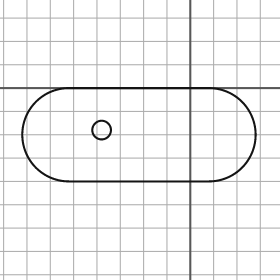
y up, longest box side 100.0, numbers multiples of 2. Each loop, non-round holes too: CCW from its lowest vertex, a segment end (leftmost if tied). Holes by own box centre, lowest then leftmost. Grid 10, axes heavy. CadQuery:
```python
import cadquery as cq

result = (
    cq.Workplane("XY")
    .moveTo(-52.0, -40.0)
    .lineTo(8.0, -40.0)
    .threePointArc((28.0, -20.0), (8.0, 0.0))
    .lineTo(-52.0, 0.0)
    .threePointArc((-72.0, -20.0), (-52.0, -40.0))
    .close()
    .moveTo(-38.0, -18.0)
    .circle(4.0)
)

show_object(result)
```